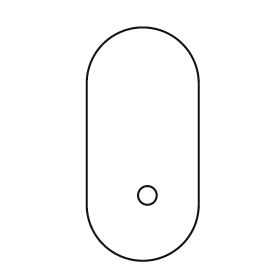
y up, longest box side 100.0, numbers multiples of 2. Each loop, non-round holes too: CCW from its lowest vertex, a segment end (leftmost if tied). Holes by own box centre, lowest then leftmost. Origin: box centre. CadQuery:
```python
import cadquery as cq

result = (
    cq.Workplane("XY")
    .moveTo(-24.0, -26.0)
    .threePointArc((0.0, -50.0), (24.0, -26.0))
    .lineTo(24.0, 26.0)
    .threePointArc((0.0, 50.0), (-24.0, 26.0))
    .close()
    .moveTo(2.0, -22.0)
    .circle(4.0)
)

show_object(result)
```